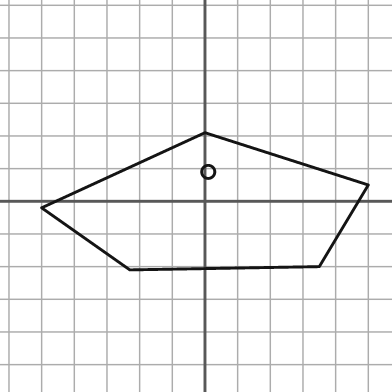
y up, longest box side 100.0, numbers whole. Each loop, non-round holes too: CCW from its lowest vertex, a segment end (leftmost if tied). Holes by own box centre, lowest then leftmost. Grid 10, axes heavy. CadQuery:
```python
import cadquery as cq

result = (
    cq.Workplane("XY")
    .moveTo(-23.0, -21.0)
    .lineTo(35.0, -20.0)
    .lineTo(50.0, 5.0)
    .lineTo(0.0, 21.0)
    .lineTo(-50.0, -2.0)
    .close()
    .moveTo(1.0, 9.0)
    .circle(2.0)
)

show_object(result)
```